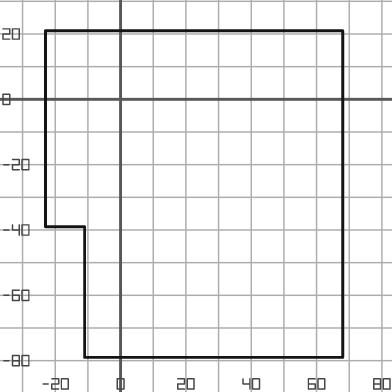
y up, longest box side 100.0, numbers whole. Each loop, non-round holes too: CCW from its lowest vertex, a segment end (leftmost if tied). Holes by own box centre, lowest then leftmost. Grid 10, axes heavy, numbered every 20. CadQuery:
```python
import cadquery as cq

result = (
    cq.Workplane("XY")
    .moveTo(-11.0, -79.0)
    .lineTo(68.0, -79.0)
    .lineTo(68.0, 21.0)
    .lineTo(-23.0, 21.0)
    .lineTo(-23.0, -39.0)
    .lineTo(-11.0, -39.0)
    .close()
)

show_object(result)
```